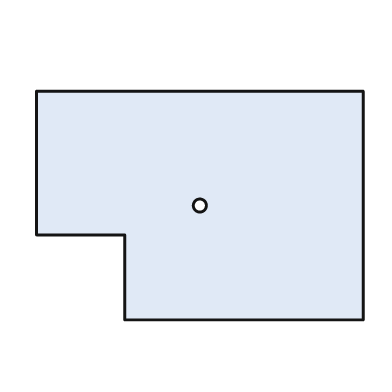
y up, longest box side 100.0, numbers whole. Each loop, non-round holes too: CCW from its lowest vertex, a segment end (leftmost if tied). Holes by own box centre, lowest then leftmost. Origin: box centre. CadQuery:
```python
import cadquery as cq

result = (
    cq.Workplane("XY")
    .moveTo(-23.0, -35.0)
    .lineTo(50.0, -35.0)
    .lineTo(50.0, 35.0)
    .lineTo(-50.0, 35.0)
    .lineTo(-50.0, -9.0)
    .lineTo(-23.0, -9.0)
    .close()
    .moveTo(0.0, 0.0)
    .circle(2.0)
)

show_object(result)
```